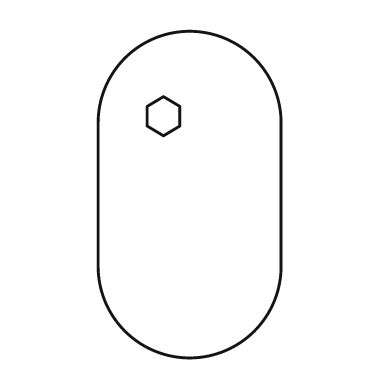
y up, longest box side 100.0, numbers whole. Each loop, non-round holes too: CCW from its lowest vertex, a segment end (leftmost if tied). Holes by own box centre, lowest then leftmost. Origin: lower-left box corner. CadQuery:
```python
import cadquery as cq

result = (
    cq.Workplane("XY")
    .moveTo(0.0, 28.0)
    .threePointArc((28.0, 0.0), (56.0, 28.0))
    .lineTo(56.0, 72.0)
    .threePointArc((28.0, 100.0), (0.0, 72.0))
    .close()
    .moveTo(20.0, 68.0)
    .lineTo(25.0, 71.0)
    .lineTo(25.0, 77.0)
    .lineTo(20.0, 80.0)
    .lineTo(15.0, 77.0)
    .lineTo(15.0, 71.0)
    .close()
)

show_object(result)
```